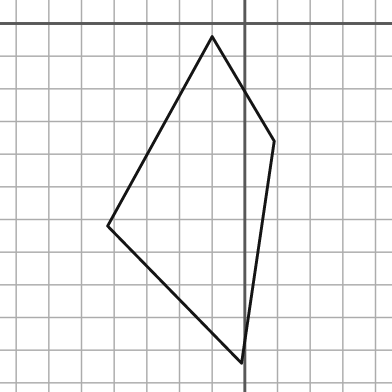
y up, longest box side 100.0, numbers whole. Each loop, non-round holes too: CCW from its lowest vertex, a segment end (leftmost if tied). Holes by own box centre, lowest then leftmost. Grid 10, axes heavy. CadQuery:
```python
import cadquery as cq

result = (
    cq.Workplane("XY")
    .moveTo(-1.0, -104.0)
    .lineTo(9.0, -36.0)
    .lineTo(-10.0, -4.0)
    .lineTo(-42.0, -62.0)
    .close()
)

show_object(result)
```